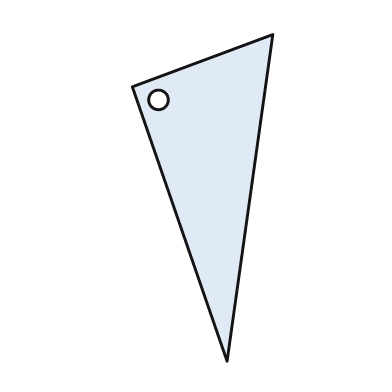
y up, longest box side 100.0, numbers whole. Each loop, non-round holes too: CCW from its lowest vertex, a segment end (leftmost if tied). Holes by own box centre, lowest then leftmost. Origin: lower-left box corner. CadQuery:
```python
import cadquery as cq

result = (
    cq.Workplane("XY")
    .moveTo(29.0, 0.0)
    .lineTo(43.0, 100.0)
    .lineTo(0.0, 84.0)
    .close()
    .moveTo(8.0, 80.0)
    .circle(3.0)
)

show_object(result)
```